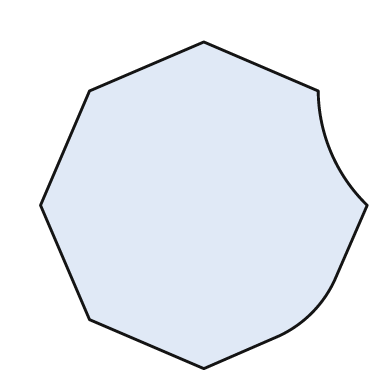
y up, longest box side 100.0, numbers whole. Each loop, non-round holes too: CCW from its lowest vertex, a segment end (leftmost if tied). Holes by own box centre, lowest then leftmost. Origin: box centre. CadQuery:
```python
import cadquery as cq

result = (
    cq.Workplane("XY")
    .moveTo(0.0, -50.0)
    .lineTo(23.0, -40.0)
    .threePointArc((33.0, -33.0), (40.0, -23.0))
    .lineTo(50.0, 0.0)
    .threePointArc((39.0, 16.0), (35.0, 35.0))
    .lineTo(0.0, 50.0)
    .lineTo(-35.0, 35.0)
    .lineTo(-50.0, 0.0)
    .lineTo(-35.0, -35.0)
    .close()
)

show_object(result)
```